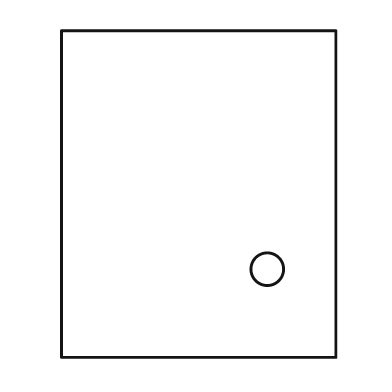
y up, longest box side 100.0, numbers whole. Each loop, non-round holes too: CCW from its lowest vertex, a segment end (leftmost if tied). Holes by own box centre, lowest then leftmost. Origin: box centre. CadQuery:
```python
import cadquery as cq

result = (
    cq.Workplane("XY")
    .moveTo(-42.0, -50.0)
    .lineTo(42.0, -50.0)
    .lineTo(42.0, 50.0)
    .lineTo(-42.0, 50.0)
    .close()
    .moveTo(21.0, -23.0)
    .circle(5.0)
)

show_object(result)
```